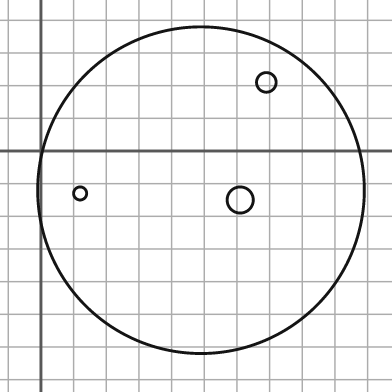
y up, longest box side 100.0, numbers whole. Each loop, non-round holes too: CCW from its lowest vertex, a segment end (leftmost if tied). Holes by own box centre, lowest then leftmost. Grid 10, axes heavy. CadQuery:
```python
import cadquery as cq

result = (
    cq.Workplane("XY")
    .moveTo(49.0, -12.0)
    .circle(50.0)
    .moveTo(61.0, -15.0)
    .circle(4.0)
    .moveTo(12.0, -13.0)
    .circle(2.0)
    .moveTo(69.0, 21.0)
    .circle(3.0)
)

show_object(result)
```